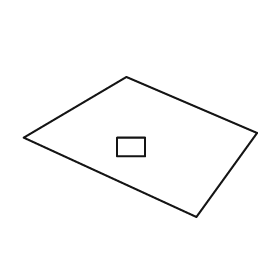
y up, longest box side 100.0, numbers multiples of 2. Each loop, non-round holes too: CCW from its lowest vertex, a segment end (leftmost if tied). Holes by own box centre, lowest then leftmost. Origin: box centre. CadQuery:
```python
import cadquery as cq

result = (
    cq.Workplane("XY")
    .moveTo(24.0, -30.0)
    .lineTo(50.0, 6.0)
    .lineTo(-6.0, 30.0)
    .lineTo(-50.0, 4.0)
    .close()
    .moveTo(-10.0, -4.0)
    .lineTo(2.0, -4.0)
    .lineTo(2.0, 4.0)
    .lineTo(-10.0, 4.0)
    .close()
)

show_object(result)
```